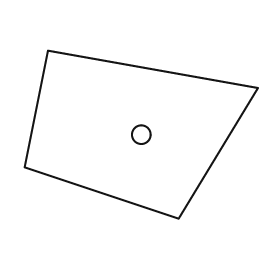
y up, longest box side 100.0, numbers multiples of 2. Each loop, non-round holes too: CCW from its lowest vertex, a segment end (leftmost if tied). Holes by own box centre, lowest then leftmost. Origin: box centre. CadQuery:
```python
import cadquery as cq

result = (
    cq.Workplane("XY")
    .moveTo(16.0, -36.0)
    .lineTo(50.0, 20.0)
    .lineTo(-40.0, 36.0)
    .lineTo(-50.0, -14.0)
    .close()
    .moveTo(0.0, 0.0)
    .circle(4.0)
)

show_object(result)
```